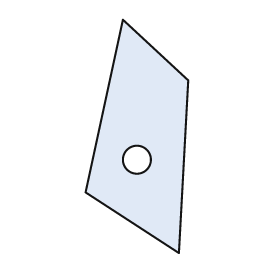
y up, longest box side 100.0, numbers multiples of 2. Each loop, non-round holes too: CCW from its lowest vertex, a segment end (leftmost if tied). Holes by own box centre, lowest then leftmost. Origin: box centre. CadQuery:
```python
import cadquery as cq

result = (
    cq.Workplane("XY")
    .moveTo(18.0, -50.0)
    .lineTo(22.0, 24.0)
    .lineTo(-6.0, 50.0)
    .lineTo(-22.0, -24.0)
    .close()
    .moveTo(0.0, -10.0)
    .circle(6.0)
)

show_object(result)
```